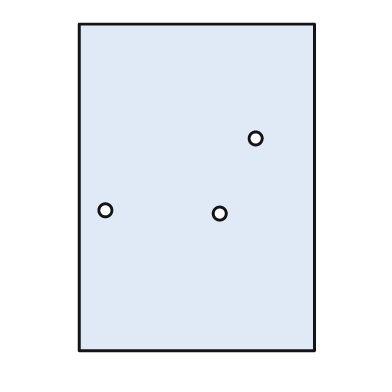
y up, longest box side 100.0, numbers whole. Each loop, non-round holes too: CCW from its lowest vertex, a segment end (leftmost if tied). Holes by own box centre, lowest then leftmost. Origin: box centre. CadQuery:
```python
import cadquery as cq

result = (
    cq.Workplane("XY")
    .moveTo(-36.0, -50.0)
    .lineTo(36.0, -50.0)
    .lineTo(36.0, 50.0)
    .lineTo(-36.0, 50.0)
    .close()
    .moveTo(7.0, -8.0)
    .circle(2.0)
    .moveTo(-28.0, -7.0)
    .circle(2.0)
    .moveTo(18.0, 15.0)
    .circle(2.0)
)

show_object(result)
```